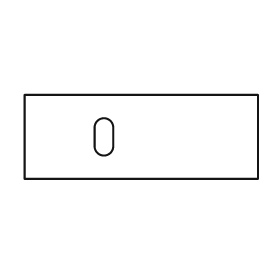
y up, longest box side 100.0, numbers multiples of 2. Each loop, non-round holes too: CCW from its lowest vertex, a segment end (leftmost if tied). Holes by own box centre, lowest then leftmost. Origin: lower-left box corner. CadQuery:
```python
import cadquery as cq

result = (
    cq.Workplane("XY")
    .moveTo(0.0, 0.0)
    .lineTo(100.0, 0.0)
    .lineTo(100.0, 36.0)
    .lineTo(0.0, 36.0)
    .close()
    .moveTo(30.0, 14.0)
    .threePointArc((34.0, 10.0), (38.0, 14.0))
    .lineTo(38.0, 22.0)
    .threePointArc((34.0, 26.0), (30.0, 22.0))
    .close()
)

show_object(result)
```